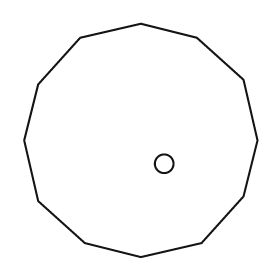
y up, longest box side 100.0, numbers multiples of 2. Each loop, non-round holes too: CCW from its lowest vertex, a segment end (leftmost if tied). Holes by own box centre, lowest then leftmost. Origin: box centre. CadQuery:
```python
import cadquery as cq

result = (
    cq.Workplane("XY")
    .moveTo(0.0, -50.0)
    .lineTo(26.0, -44.0)
    .lineTo(44.0, -24.0)
    .lineTo(50.0, 0.0)
    .lineTo(44.0, 26.0)
    .lineTo(24.0, 44.0)
    .lineTo(0.0, 50.0)
    .lineTo(-26.0, 44.0)
    .lineTo(-44.0, 24.0)
    .lineTo(-50.0, 0.0)
    .lineTo(-44.0, -26.0)
    .lineTo(-24.0, -44.0)
    .close()
    .moveTo(10.0, -10.0)
    .circle(4.0)
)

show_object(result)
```